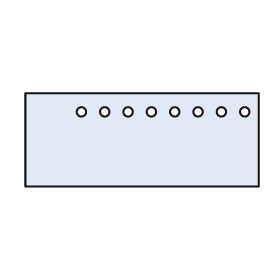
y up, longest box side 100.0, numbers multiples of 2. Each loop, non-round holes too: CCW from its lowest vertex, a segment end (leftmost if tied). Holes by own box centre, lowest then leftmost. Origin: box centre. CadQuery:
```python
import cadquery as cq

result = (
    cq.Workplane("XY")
    .moveTo(-50.0, -20.0)
    .lineTo(50.0, -20.0)
    .lineTo(50.0, 20.0)
    .lineTo(-50.0, 20.0)
    .close()
    .moveTo(-26.0, 12.0)
    .circle(2.0)
    .moveTo(-16.0, 12.0)
    .circle(2.0)
    .moveTo(-6.0, 12.0)
    .circle(2.0)
    .moveTo(4.0, 12.0)
    .circle(2.0)
    .moveTo(14.0, 12.0)
    .circle(2.0)
    .moveTo(24.0, 12.0)
    .circle(2.0)
    .moveTo(34.0, 12.0)
    .circle(2.0)
    .moveTo(44.0, 12.0)
    .circle(2.0)
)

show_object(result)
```